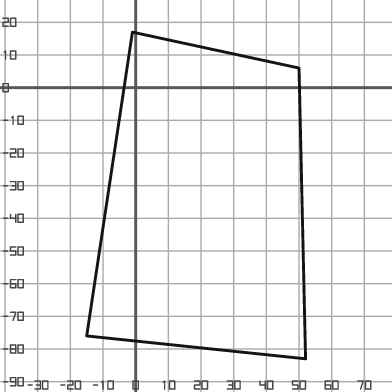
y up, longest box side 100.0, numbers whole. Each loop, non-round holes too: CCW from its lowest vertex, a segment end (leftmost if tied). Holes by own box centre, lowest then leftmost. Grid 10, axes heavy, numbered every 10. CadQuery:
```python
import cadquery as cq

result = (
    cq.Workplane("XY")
    .moveTo(52.0, -83.0)
    .lineTo(50.0, 6.0)
    .lineTo(-1.0, 17.0)
    .lineTo(-15.0, -76.0)
    .close()
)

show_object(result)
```